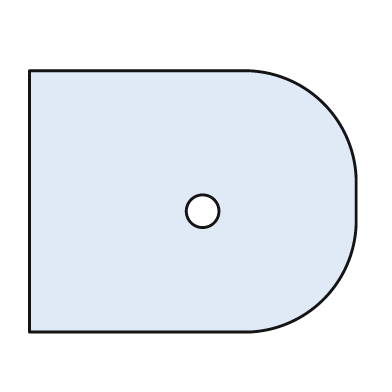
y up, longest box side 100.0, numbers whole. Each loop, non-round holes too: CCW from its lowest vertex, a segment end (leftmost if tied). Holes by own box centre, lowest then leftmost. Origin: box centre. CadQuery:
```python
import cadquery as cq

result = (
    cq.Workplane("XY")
    .moveTo(-50.0, -40.0)
    .lineTo(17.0, -40.0)
    .threePointArc((40.0, -30.0), (50.0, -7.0))
    .lineTo(50.0, 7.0)
    .threePointArc((40.0, 30.0), (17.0, 40.0))
    .lineTo(-50.0, 40.0)
    .close()
    .moveTo(3.0, -3.0)
    .circle(5.0)
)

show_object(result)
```